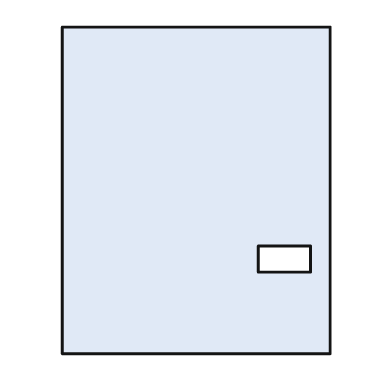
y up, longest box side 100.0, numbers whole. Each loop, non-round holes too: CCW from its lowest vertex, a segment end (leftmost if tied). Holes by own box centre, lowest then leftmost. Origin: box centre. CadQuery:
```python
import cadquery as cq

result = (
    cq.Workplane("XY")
    .moveTo(-41.0, -50.0)
    .lineTo(41.0, -50.0)
    .lineTo(41.0, 50.0)
    .lineTo(-41.0, 50.0)
    .close()
    .moveTo(19.0, -25.0)
    .lineTo(35.0, -25.0)
    .lineTo(35.0, -17.0)
    .lineTo(19.0, -17.0)
    .close()
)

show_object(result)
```